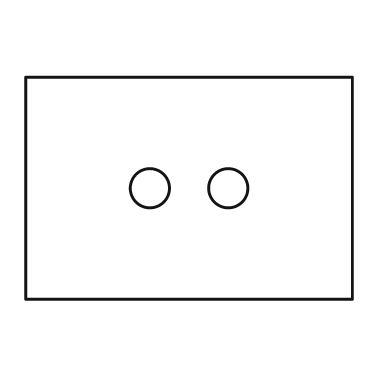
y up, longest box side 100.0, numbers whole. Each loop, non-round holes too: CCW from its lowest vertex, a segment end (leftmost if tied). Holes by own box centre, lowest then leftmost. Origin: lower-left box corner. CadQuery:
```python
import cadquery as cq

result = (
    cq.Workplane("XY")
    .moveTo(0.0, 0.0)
    .lineTo(100.0, 0.0)
    .lineTo(100.0, 68.0)
    .lineTo(0.0, 68.0)
    .close()
    .moveTo(38.0, 34.0)
    .circle(6.0)
    .moveTo(62.0, 34.0)
    .circle(6.0)
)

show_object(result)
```